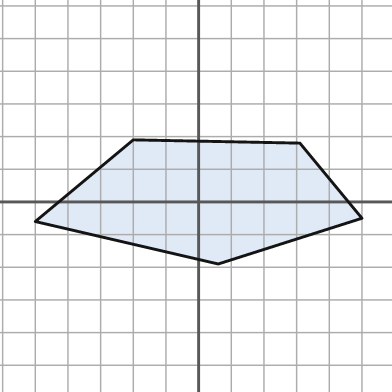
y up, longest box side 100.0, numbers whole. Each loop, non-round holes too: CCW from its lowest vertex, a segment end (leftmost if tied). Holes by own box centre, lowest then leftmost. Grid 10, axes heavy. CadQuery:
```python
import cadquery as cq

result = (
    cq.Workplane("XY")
    .moveTo(6.0, -19.0)
    .lineTo(50.0, -5.0)
    .lineTo(31.0, 18.0)
    .lineTo(-20.0, 19.0)
    .lineTo(-50.0, -6.0)
    .close()
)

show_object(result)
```